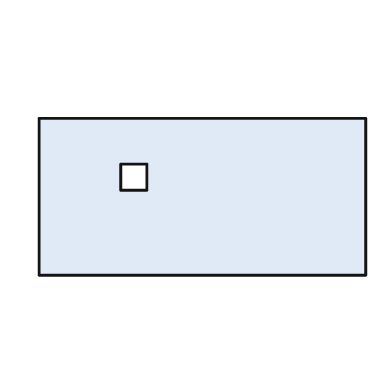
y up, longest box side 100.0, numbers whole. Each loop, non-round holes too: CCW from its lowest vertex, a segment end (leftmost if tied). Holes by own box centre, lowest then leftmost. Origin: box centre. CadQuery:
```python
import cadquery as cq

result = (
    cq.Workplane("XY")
    .moveTo(-50.0, -24.0)
    .lineTo(50.0, -24.0)
    .lineTo(50.0, 24.0)
    .lineTo(-50.0, 24.0)
    .close()
    .moveTo(-25.0, 2.0)
    .lineTo(-17.0, 2.0)
    .lineTo(-17.0, 10.0)
    .lineTo(-25.0, 10.0)
    .close()
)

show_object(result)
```